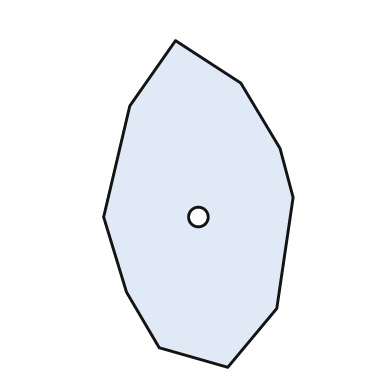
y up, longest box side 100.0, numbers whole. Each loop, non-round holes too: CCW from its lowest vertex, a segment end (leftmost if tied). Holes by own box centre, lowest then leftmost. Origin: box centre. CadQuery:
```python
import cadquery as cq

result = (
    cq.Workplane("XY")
    .moveTo(9.0, -50.0)
    .lineTo(24.0, -32.0)
    .lineTo(29.0, 2.0)
    .lineTo(25.0, 17.0)
    .lineTo(13.0, 37.0)
    .lineTo(-7.0, 50.0)
    .lineTo(-21.0, 30.0)
    .lineTo(-29.0, -4.0)
    .lineTo(-22.0, -27.0)
    .lineTo(-12.0, -44.0)
    .close()
    .moveTo(0.0, -4.0)
    .circle(3.0)
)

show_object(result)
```